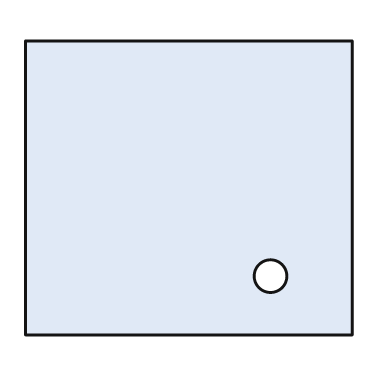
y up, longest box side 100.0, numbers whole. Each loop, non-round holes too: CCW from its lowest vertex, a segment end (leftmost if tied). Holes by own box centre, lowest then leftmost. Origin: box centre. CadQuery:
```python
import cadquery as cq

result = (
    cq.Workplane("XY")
    .moveTo(-50.0, -45.0)
    .lineTo(50.0, -45.0)
    .lineTo(50.0, 45.0)
    .lineTo(-50.0, 45.0)
    .close()
    .moveTo(25.0, -27.0)
    .circle(5.0)
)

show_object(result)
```